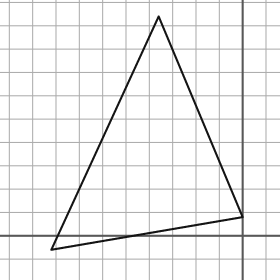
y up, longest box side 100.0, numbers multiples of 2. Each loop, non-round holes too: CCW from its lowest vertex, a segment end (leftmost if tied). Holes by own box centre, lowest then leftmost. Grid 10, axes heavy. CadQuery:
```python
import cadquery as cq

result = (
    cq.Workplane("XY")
    .moveTo(-82.0, -6.0)
    .lineTo(0.0, 8.0)
    .lineTo(-36.0, 94.0)
    .close()
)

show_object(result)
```